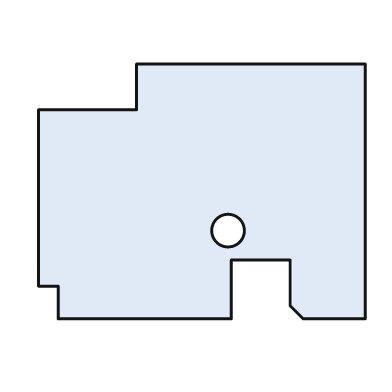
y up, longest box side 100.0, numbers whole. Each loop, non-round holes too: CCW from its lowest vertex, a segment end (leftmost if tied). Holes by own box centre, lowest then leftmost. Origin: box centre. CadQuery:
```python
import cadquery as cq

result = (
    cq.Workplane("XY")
    .moveTo(-44.0, -39.0)
    .lineTo(9.0, -39.0)
    .lineTo(9.0, -21.0)
    .lineTo(27.0, -21.0)
    .lineTo(27.0, -35.0)
    .lineTo(31.0, -39.0)
    .lineTo(50.0, -39.0)
    .lineTo(50.0, 39.0)
    .lineTo(-20.0, 39.0)
    .lineTo(-20.0, 25.0)
    .lineTo(-50.0, 25.0)
    .lineTo(-50.0, -29.0)
    .lineTo(-44.0, -29.0)
    .close()
    .moveTo(8.0, -12.0)
    .circle(5.0)
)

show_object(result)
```